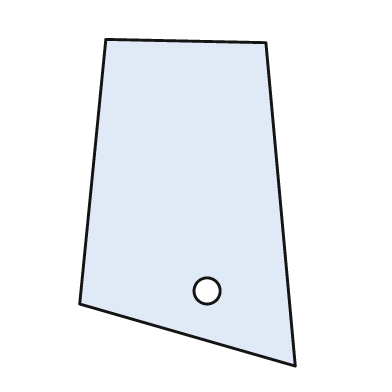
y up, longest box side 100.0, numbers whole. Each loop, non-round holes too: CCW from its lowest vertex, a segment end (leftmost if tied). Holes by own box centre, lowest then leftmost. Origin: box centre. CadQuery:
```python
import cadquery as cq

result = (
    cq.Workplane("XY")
    .moveTo(33.0, -50.0)
    .lineTo(24.0, 49.0)
    .lineTo(-25.0, 50.0)
    .lineTo(-33.0, -31.0)
    .close()
    .moveTo(6.0, -27.0)
    .circle(4.0)
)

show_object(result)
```